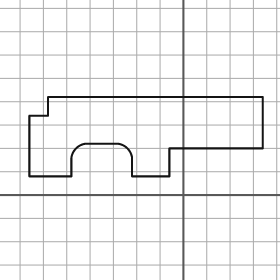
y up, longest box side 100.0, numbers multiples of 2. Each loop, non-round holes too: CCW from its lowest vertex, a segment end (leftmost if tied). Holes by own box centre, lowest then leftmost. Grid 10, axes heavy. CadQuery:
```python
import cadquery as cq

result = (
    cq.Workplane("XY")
    .moveTo(-66.0, 8.0)
    .lineTo(-48.0, 8.0)
    .lineTo(-48.0, 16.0)
    .threePointArc((-46.0, 20.0), (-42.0, 22.0))
    .lineTo(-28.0, 22.0)
    .threePointArc((-24.0, 20.0), (-22.0, 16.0))
    .lineTo(-22.0, 8.0)
    .lineTo(-6.0, 8.0)
    .lineTo(-6.0, 20.0)
    .lineTo(34.0, 20.0)
    .lineTo(34.0, 42.0)
    .lineTo(-58.0, 42.0)
    .lineTo(-58.0, 34.0)
    .lineTo(-66.0, 34.0)
    .close()
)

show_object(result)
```